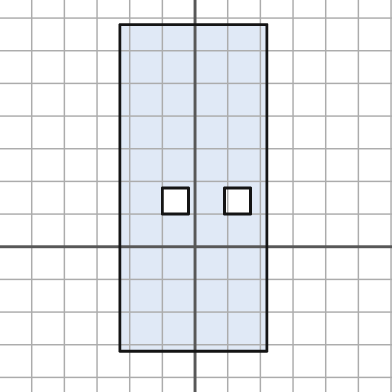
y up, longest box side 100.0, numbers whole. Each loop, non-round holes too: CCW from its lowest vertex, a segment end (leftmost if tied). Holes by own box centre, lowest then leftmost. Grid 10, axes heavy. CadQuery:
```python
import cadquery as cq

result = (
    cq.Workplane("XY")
    .moveTo(-23.0, -32.0)
    .lineTo(22.0, -32.0)
    .lineTo(22.0, 68.0)
    .lineTo(-23.0, 68.0)
    .close()
    .moveTo(-10.0, 10.0)
    .lineTo(-2.0, 10.0)
    .lineTo(-2.0, 18.0)
    .lineTo(-10.0, 18.0)
    .close()
    .moveTo(9.0, 10.0)
    .lineTo(17.0, 10.0)
    .lineTo(17.0, 18.0)
    .lineTo(9.0, 18.0)
    .close()
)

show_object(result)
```